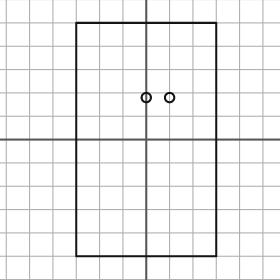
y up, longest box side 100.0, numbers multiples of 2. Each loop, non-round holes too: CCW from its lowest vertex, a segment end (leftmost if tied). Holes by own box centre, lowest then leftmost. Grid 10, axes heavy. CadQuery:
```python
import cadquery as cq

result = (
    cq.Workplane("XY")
    .moveTo(-30.0, -50.0)
    .lineTo(30.0, -50.0)
    .lineTo(30.0, 50.0)
    .lineTo(-30.0, 50.0)
    .close()
    .moveTo(0.0, 18.0)
    .circle(2.0)
    .moveTo(10.0, 18.0)
    .circle(2.0)
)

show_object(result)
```